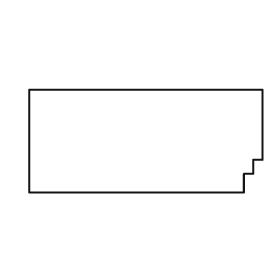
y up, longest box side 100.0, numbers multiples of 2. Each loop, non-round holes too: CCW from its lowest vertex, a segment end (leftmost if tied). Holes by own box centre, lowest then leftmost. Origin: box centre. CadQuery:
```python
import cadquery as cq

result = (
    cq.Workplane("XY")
    .moveTo(-50.0, -22.0)
    .lineTo(42.0, -22.0)
    .lineTo(42.0, -14.0)
    .lineTo(46.0, -14.0)
    .lineTo(46.0, -8.0)
    .lineTo(50.0, -8.0)
    .lineTo(50.0, 22.0)
    .lineTo(-50.0, 22.0)
    .close()
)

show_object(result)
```